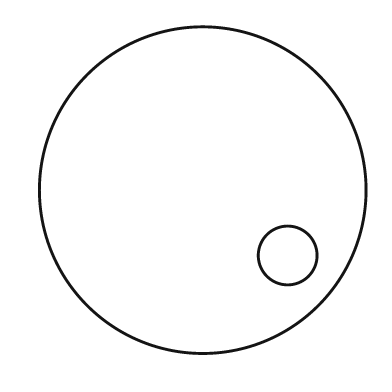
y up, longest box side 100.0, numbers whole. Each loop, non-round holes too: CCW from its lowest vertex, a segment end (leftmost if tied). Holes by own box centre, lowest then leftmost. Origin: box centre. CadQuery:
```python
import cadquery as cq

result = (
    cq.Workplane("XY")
    .moveTo(0.0, 0.0)
    .circle(50.0)
    .moveTo(26.0, -20.0)
    .circle(9.0)
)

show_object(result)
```